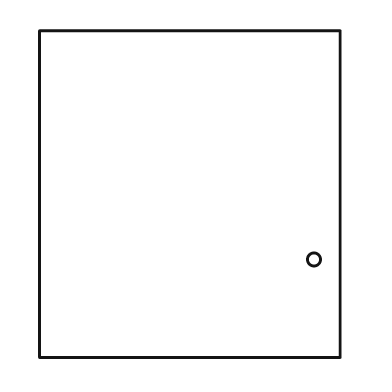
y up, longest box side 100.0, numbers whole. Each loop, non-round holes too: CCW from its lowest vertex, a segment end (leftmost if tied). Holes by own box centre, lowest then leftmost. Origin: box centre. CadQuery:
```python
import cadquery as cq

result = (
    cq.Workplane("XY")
    .moveTo(-46.0, -50.0)
    .lineTo(46.0, -50.0)
    .lineTo(46.0, 50.0)
    .lineTo(-46.0, 50.0)
    .close()
    .moveTo(38.0, -20.0)
    .circle(2.0)
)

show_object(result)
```